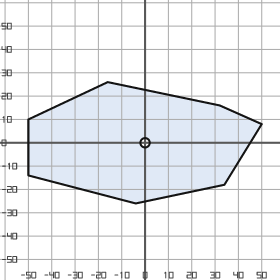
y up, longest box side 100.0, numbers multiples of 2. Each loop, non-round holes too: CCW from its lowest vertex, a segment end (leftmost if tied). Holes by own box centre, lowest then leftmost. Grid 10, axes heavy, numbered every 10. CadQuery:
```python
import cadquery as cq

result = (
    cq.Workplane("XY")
    .moveTo(-4.0, -26.0)
    .lineTo(34.0, -18.0)
    .lineTo(50.0, 8.0)
    .lineTo(32.0, 16.0)
    .lineTo(-16.0, 26.0)
    .lineTo(-50.0, 10.0)
    .lineTo(-50.0, -14.0)
    .close()
    .moveTo(0.0, 0.0)
    .circle(2.0)
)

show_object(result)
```